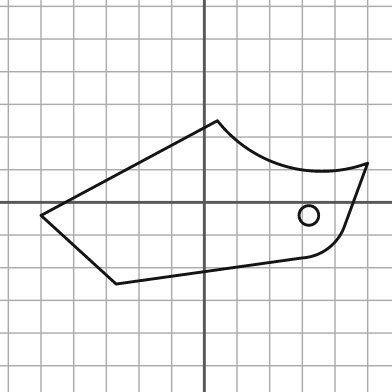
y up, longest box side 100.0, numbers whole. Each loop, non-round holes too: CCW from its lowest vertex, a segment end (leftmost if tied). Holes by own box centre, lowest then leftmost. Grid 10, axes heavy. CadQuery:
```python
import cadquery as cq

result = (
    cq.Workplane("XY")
    .moveTo(-27.0, -25.0)
    .lineTo(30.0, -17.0)
    .threePointArc((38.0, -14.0), (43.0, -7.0))
    .lineTo(50.0, 12.0)
    .threePointArc((25.0, 11.0), (4.0, 25.0))
    .lineTo(-50.0, -4.0)
    .close()
    .moveTo(32.0, -4.0)
    .circle(3.0)
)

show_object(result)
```